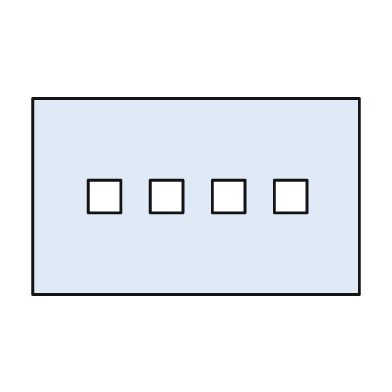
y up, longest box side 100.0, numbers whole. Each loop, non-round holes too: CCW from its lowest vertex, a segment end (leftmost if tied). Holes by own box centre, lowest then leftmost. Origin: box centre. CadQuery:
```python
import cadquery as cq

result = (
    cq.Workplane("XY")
    .moveTo(-50.0, -30.0)
    .lineTo(50.0, -30.0)
    .lineTo(50.0, 30.0)
    .lineTo(-50.0, 30.0)
    .close()
    .moveTo(-33.0, -5.0)
    .lineTo(-23.0, -5.0)
    .lineTo(-23.0, 5.0)
    .lineTo(-33.0, 5.0)
    .close()
    .moveTo(-14.0, -5.0)
    .lineTo(-4.0, -5.0)
    .lineTo(-4.0, 5.0)
    .lineTo(-14.0, 5.0)
    .close()
    .moveTo(5.0, -5.0)
    .lineTo(15.0, -5.0)
    .lineTo(15.0, 5.0)
    .lineTo(5.0, 5.0)
    .close()
    .moveTo(24.0, -5.0)
    .lineTo(34.0, -5.0)
    .lineTo(34.0, 5.0)
    .lineTo(24.0, 5.0)
    .close()
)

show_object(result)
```